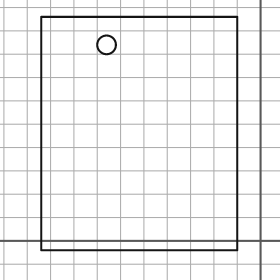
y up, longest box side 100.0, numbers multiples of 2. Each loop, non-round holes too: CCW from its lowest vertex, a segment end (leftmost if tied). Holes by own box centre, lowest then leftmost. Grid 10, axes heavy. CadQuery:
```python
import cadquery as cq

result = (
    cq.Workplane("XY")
    .moveTo(-94.0, -4.0)
    .lineTo(-10.0, -4.0)
    .lineTo(-10.0, 96.0)
    .lineTo(-94.0, 96.0)
    .close()
    .moveTo(-66.0, 84.0)
    .circle(4.0)
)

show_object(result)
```